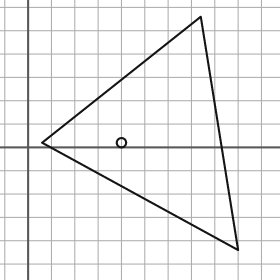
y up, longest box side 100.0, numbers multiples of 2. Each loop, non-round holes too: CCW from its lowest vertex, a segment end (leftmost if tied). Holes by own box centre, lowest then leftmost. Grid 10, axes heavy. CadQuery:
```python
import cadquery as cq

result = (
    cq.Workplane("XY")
    .moveTo(90.0, -44.0)
    .lineTo(74.0, 56.0)
    .lineTo(6.0, 2.0)
    .close()
    .moveTo(40.0, 2.0)
    .circle(2.0)
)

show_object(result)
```